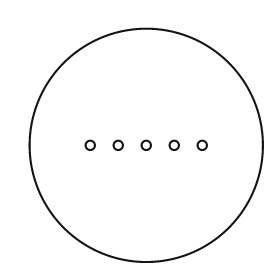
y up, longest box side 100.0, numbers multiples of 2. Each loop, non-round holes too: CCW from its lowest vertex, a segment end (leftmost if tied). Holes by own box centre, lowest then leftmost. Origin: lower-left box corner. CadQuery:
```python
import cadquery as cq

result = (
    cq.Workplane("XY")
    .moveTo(50.0, 50.0)
    .circle(50.0)
    .moveTo(26.0, 50.0)
    .circle(2.0)
    .moveTo(38.0, 50.0)
    .circle(2.0)
    .moveTo(50.0, 50.0)
    .circle(2.0)
    .moveTo(62.0, 50.0)
    .circle(2.0)
    .moveTo(74.0, 50.0)
    .circle(2.0)
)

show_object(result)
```